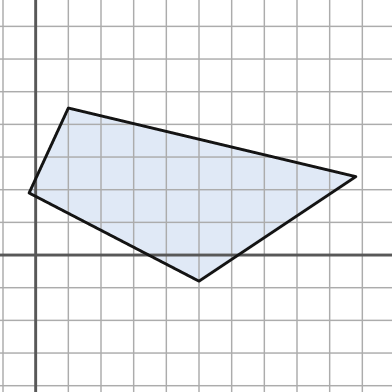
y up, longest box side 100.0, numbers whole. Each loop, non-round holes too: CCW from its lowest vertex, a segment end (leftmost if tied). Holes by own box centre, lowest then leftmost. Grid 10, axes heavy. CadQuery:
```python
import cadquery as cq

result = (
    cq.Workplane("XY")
    .moveTo(50.0, -8.0)
    .lineTo(98.0, 24.0)
    .lineTo(10.0, 45.0)
    .lineTo(-2.0, 19.0)
    .close()
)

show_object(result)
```